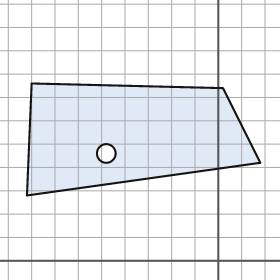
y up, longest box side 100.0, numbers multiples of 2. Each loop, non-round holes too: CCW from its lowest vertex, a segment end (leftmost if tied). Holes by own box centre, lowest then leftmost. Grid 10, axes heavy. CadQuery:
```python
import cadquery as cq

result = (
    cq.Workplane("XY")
    .moveTo(-82.0, 28.0)
    .lineTo(18.0, 42.0)
    .lineTo(2.0, 74.0)
    .lineTo(-80.0, 76.0)
    .close()
    .moveTo(-48.0, 46.0)
    .circle(4.0)
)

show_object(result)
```